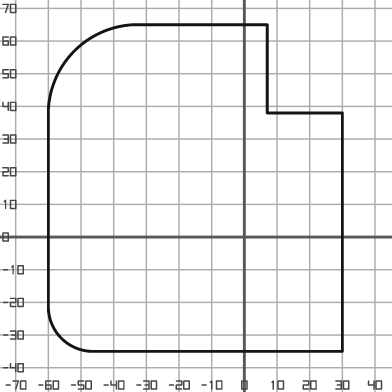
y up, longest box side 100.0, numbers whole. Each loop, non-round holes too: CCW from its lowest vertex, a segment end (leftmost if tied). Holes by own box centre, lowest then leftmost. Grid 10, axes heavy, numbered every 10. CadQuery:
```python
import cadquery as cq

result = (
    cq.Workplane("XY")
    .moveTo(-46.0, -35.0)
    .lineTo(30.0, -35.0)
    .lineTo(30.0, 38.0)
    .lineTo(7.0, 38.0)
    .lineTo(7.0, 65.0)
    .lineTo(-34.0, 65.0)
    .threePointArc((-52.0, 57.0), (-60.0, 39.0))
    .lineTo(-60.0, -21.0)
    .threePointArc((-56.0, -31.0), (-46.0, -35.0))
    .close()
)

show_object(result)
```